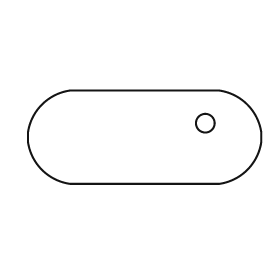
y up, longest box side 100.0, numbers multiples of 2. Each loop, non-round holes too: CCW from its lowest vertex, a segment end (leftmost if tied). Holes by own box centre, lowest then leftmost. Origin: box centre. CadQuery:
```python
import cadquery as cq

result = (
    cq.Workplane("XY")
    .moveTo(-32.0, -20.0)
    .lineTo(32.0, -20.0)
    .threePointArc((44.0, -14.0), (50.0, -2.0))
    .lineTo(50.0, 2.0)
    .threePointArc((44.0, 14.0), (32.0, 20.0))
    .lineTo(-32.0, 20.0)
    .threePointArc((-44.0, 14.0), (-50.0, 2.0))
    .lineTo(-50.0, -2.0)
    .threePointArc((-44.0, -14.0), (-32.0, -20.0))
    .close()
    .moveTo(26.0, 6.0)
    .circle(4.0)
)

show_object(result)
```